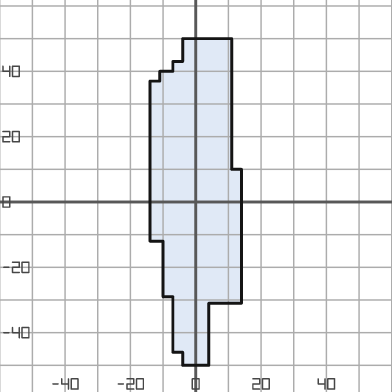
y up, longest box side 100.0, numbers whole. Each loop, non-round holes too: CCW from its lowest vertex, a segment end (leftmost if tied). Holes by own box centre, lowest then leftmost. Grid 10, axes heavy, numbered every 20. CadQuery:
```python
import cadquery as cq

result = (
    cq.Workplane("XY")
    .moveTo(-4.0, -50.0)
    .lineTo(4.0, -50.0)
    .lineTo(4.0, -31.0)
    .lineTo(14.0, -31.0)
    .lineTo(14.0, 10.0)
    .lineTo(11.0, 10.0)
    .lineTo(11.0, 50.0)
    .lineTo(-4.0, 50.0)
    .lineTo(-4.0, 43.0)
    .lineTo(-7.0, 43.0)
    .lineTo(-7.0, 40.0)
    .lineTo(-11.0, 40.0)
    .lineTo(-11.0, 37.0)
    .lineTo(-14.0, 37.0)
    .lineTo(-14.0, -12.0)
    .lineTo(-10.0, -12.0)
    .lineTo(-10.0, -29.0)
    .lineTo(-7.0, -29.0)
    .lineTo(-7.0, -46.0)
    .lineTo(-4.0, -46.0)
    .close()
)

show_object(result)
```